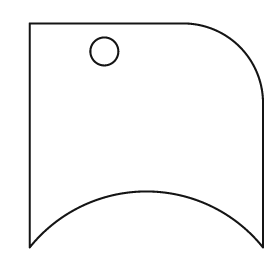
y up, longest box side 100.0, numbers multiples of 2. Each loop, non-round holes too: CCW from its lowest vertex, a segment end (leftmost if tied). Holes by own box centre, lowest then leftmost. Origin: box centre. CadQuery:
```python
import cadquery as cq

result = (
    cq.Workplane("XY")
    .moveTo(-50.0, -48.0)
    .threePointArc((0.0, -24.0), (50.0, -48.0))
    .lineTo(50.0, 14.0)
    .threePointArc((40.0, 38.0), (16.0, 48.0))
    .lineTo(-50.0, 48.0)
    .close()
    .moveTo(-18.0, 36.0)
    .circle(6.0)
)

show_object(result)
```